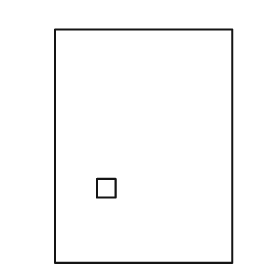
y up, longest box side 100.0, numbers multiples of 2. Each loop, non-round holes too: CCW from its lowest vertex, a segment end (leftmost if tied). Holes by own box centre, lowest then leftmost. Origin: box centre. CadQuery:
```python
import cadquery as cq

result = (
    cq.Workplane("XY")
    .moveTo(-38.0, -50.0)
    .lineTo(38.0, -50.0)
    .lineTo(38.0, 50.0)
    .lineTo(-38.0, 50.0)
    .close()
    .moveTo(-20.0, -22.0)
    .lineTo(-12.0, -22.0)
    .lineTo(-12.0, -14.0)
    .lineTo(-20.0, -14.0)
    .close()
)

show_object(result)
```